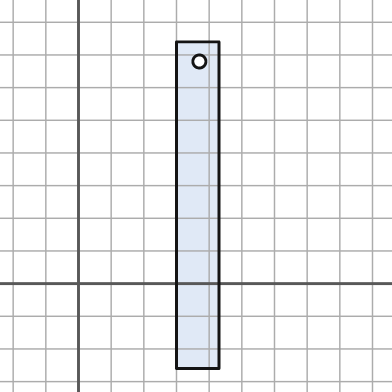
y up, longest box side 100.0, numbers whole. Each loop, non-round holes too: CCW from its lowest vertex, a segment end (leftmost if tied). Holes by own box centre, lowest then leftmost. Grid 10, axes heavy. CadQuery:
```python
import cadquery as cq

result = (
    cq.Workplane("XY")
    .moveTo(30.0, -26.0)
    .lineTo(43.0, -26.0)
    .lineTo(43.0, 74.0)
    .lineTo(30.0, 74.0)
    .close()
    .moveTo(37.0, 68.0)
    .circle(2.0)
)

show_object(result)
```